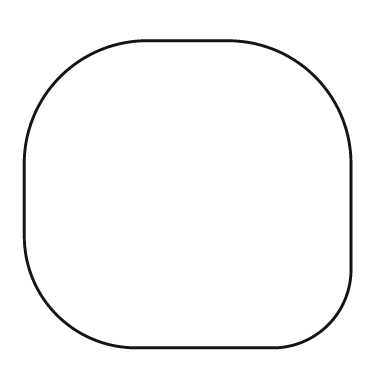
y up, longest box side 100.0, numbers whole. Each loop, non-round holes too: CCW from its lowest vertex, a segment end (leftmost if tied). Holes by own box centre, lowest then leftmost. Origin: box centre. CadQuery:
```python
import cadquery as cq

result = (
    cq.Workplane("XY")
    .moveTo(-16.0, -47.0)
    .lineTo(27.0, -47.0)
    .threePointArc((43.0, -40.0), (50.0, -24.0))
    .lineTo(50.0, 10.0)
    .threePointArc((39.0, 36.0), (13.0, 47.0))
    .lineTo(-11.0, 47.0)
    .threePointArc((-39.0, 36.0), (-50.0, 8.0))
    .lineTo(-50.0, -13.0)
    .threePointArc((-40.0, -37.0), (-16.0, -47.0))
    .close()
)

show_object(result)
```